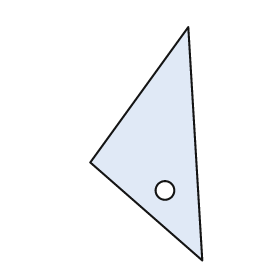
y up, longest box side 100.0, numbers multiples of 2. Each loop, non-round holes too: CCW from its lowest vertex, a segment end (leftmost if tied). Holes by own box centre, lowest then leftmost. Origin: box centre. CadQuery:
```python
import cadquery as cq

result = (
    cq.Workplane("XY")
    .moveTo(24.0, -50.0)
    .lineTo(18.0, 50.0)
    .lineTo(-24.0, -8.0)
    .close()
    .moveTo(8.0, -20.0)
    .circle(4.0)
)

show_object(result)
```